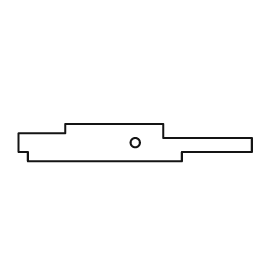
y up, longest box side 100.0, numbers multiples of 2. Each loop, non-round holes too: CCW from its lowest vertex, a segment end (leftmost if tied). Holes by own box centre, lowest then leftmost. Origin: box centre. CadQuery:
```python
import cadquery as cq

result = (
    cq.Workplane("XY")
    .moveTo(-46.0, -8.0)
    .lineTo(20.0, -8.0)
    .lineTo(20.0, -4.0)
    .lineTo(50.0, -4.0)
    .lineTo(50.0, 2.0)
    .lineTo(12.0, 2.0)
    .lineTo(12.0, 8.0)
    .lineTo(-30.0, 8.0)
    .lineTo(-30.0, 4.0)
    .lineTo(-50.0, 4.0)
    .lineTo(-50.0, -4.0)
    .lineTo(-46.0, -4.0)
    .close()
    .moveTo(0.0, 0.0)
    .circle(2.0)
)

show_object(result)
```